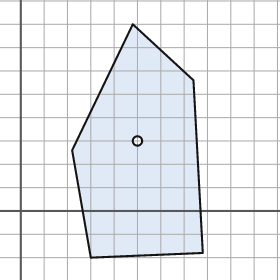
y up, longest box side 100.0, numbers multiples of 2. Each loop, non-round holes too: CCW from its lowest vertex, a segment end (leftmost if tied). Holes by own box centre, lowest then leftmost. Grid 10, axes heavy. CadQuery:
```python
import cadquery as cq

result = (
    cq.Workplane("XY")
    .moveTo(30.0, -20.0)
    .lineTo(78.0, -18.0)
    .lineTo(74.0, 56.0)
    .lineTo(48.0, 80.0)
    .lineTo(22.0, 26.0)
    .close()
    .moveTo(50.0, 30.0)
    .circle(2.0)
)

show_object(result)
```